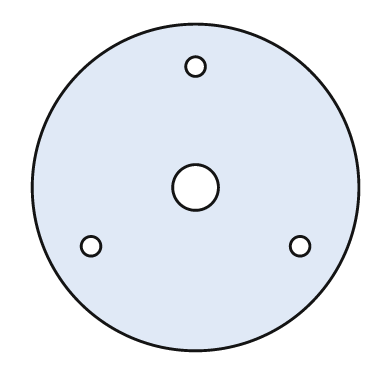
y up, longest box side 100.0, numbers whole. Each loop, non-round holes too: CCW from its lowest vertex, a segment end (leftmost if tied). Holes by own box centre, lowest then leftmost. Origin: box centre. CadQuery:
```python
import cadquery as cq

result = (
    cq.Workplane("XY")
    .moveTo(0.0, 0.0)
    .circle(50.0)
    .moveTo(-32.0, -18.0)
    .circle(3.0)
    .moveTo(32.0, -18.0)
    .circle(3.0)
    .moveTo(0.0, 0.0)
    .circle(7.0)
    .moveTo(0.0, 37.0)
    .circle(3.0)
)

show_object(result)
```